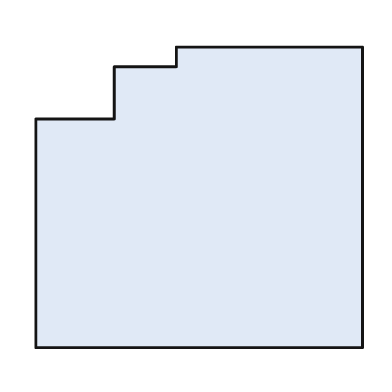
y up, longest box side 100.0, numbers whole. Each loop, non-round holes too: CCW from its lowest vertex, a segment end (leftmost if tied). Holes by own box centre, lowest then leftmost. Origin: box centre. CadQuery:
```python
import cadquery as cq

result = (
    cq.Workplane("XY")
    .moveTo(-50.0, -46.0)
    .lineTo(50.0, -46.0)
    .lineTo(50.0, 46.0)
    .lineTo(-7.0, 46.0)
    .lineTo(-7.0, 40.0)
    .lineTo(-26.0, 40.0)
    .lineTo(-26.0, 24.0)
    .lineTo(-50.0, 24.0)
    .close()
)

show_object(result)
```